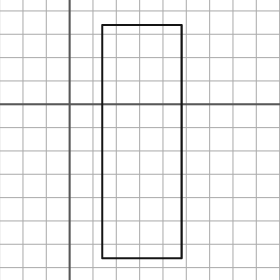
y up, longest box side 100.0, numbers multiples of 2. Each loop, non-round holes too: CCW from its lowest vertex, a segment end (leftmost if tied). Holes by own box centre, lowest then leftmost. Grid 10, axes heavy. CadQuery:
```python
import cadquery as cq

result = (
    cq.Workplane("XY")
    .moveTo(14.0, -66.0)
    .lineTo(48.0, -66.0)
    .lineTo(48.0, 34.0)
    .lineTo(14.0, 34.0)
    .close()
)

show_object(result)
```